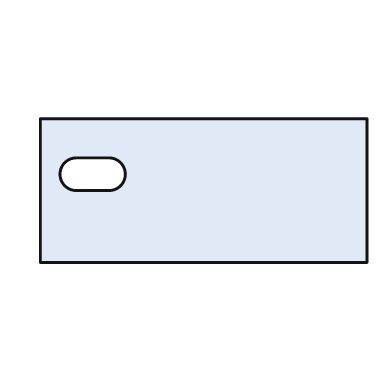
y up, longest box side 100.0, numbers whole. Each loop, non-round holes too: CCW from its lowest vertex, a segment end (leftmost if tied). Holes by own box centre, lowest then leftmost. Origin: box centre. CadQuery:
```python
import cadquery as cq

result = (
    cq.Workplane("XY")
    .moveTo(-50.0, -22.0)
    .lineTo(50.0, -22.0)
    .lineTo(50.0, 22.0)
    .lineTo(-50.0, 22.0)
    .close()
    .moveTo(-39.0, 0.0)
    .lineTo(-29.0, 0.0)
    .threePointArc((-24.0, 5.0), (-29.0, 10.0))
    .lineTo(-39.0, 10.0)
    .threePointArc((-44.0, 5.0), (-39.0, 0.0))
    .close()
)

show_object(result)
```